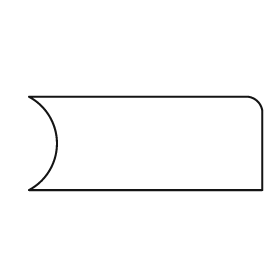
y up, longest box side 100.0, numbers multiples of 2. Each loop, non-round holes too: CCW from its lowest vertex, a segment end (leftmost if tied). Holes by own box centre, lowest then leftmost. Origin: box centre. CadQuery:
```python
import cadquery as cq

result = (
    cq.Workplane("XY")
    .moveTo(-50.0, -20.0)
    .lineTo(50.0, -20.0)
    .lineTo(50.0, 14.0)
    .threePointArc((48.0, 18.0), (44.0, 20.0))
    .lineTo(-50.0, 20.0)
    .threePointArc((-38.0, 0.0), (-50.0, -20.0))
    .close()
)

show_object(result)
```